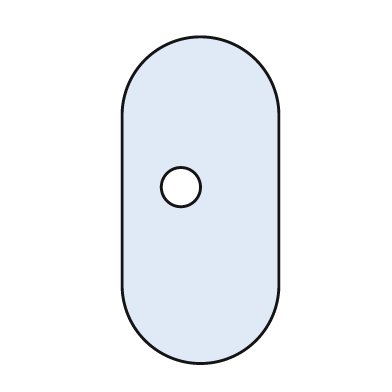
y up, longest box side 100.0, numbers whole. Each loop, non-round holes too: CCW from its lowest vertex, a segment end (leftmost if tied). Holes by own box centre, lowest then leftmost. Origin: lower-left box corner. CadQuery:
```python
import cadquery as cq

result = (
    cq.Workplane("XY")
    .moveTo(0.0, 24.0)
    .threePointArc((24.0, 0.0), (48.0, 24.0))
    .lineTo(48.0, 76.0)
    .threePointArc((24.0, 100.0), (0.0, 76.0))
    .close()
    .moveTo(18.0, 54.0)
    .circle(6.0)
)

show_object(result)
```